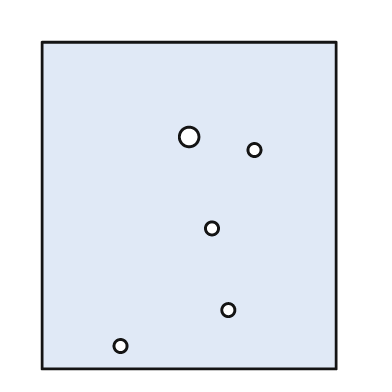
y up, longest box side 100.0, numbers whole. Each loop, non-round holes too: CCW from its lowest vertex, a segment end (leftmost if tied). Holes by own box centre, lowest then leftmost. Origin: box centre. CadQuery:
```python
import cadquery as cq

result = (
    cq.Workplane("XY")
    .moveTo(-45.0, -50.0)
    .lineTo(45.0, -50.0)
    .lineTo(45.0, 50.0)
    .lineTo(-45.0, 50.0)
    .close()
    .moveTo(-21.0, -43.0)
    .circle(2.0)
    .moveTo(12.0, -32.0)
    .circle(2.0)
    .moveTo(7.0, -7.0)
    .circle(2.0)
    .moveTo(20.0, 17.0)
    .circle(2.0)
    .moveTo(0.0, 21.0)
    .circle(3.0)
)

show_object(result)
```